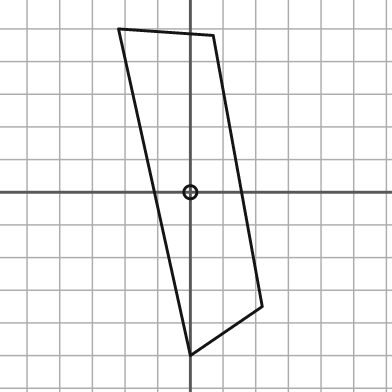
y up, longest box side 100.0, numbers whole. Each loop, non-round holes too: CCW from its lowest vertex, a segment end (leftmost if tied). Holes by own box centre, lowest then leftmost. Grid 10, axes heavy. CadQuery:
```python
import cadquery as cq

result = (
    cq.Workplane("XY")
    .moveTo(0.0, -50.0)
    .lineTo(22.0, -35.0)
    .lineTo(7.0, 48.0)
    .lineTo(-22.0, 50.0)
    .close()
    .moveTo(0.0, 0.0)
    .circle(2.0)
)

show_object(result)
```